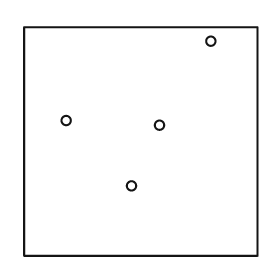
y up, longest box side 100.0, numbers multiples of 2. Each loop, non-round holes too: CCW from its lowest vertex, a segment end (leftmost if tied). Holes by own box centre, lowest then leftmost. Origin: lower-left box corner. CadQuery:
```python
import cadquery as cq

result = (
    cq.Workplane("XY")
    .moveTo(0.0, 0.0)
    .lineTo(100.0, 0.0)
    .lineTo(100.0, 98.0)
    .lineTo(0.0, 98.0)
    .close()
    .moveTo(46.0, 30.0)
    .circle(2.0)
    .moveTo(58.0, 56.0)
    .circle(2.0)
    .moveTo(18.0, 58.0)
    .circle(2.0)
    .moveTo(80.0, 92.0)
    .circle(2.0)
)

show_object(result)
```